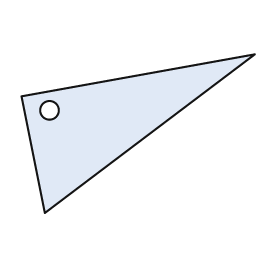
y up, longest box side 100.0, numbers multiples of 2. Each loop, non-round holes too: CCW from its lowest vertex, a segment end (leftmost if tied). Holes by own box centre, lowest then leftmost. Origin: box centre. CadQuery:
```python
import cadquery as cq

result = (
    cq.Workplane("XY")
    .moveTo(-40.0, -34.0)
    .lineTo(50.0, 34.0)
    .lineTo(-50.0, 16.0)
    .close()
    .moveTo(-38.0, 10.0)
    .circle(4.0)
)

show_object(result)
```